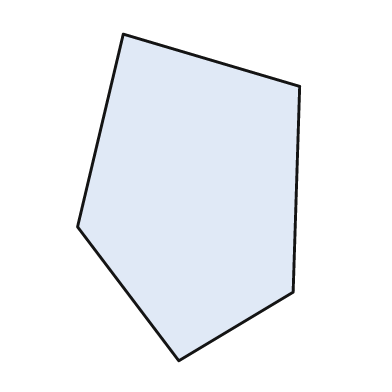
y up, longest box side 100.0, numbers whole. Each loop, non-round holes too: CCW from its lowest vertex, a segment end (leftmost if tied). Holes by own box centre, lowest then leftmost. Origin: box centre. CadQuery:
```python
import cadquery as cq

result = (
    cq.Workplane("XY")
    .moveTo(-3.0, -50.0)
    .lineTo(32.0, -29.0)
    .lineTo(34.0, 34.0)
    .lineTo(-20.0, 50.0)
    .lineTo(-34.0, -9.0)
    .close()
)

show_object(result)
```